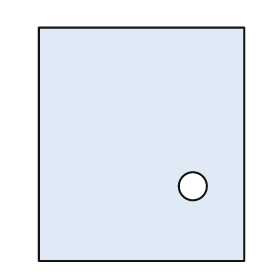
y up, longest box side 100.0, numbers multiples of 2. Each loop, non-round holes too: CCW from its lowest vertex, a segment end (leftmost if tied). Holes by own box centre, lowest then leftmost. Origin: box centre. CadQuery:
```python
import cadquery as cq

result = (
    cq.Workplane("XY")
    .moveTo(-44.0, -50.0)
    .lineTo(44.0, -50.0)
    .lineTo(44.0, 50.0)
    .lineTo(-44.0, 50.0)
    .close()
    .moveTo(22.0, -18.0)
    .circle(6.0)
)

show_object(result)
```